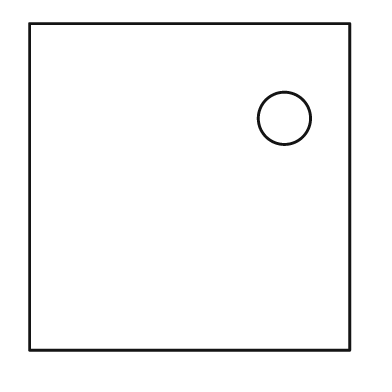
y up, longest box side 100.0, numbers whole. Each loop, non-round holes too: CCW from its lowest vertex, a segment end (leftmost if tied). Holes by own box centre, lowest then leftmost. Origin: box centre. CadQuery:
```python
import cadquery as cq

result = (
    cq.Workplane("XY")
    .moveTo(-49.0, -50.0)
    .lineTo(49.0, -50.0)
    .lineTo(49.0, 50.0)
    .lineTo(-49.0, 50.0)
    .close()
    .moveTo(29.0, 21.0)
    .circle(8.0)
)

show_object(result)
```